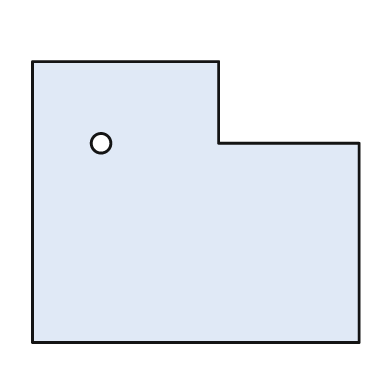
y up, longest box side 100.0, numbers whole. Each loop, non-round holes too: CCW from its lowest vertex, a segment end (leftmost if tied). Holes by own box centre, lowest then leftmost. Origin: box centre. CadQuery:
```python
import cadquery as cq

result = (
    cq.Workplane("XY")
    .moveTo(-50.0, -43.0)
    .lineTo(50.0, -43.0)
    .lineTo(50.0, 18.0)
    .lineTo(7.0, 18.0)
    .lineTo(7.0, 43.0)
    .lineTo(-50.0, 43.0)
    .close()
    .moveTo(-29.0, 18.0)
    .circle(3.0)
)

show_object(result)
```